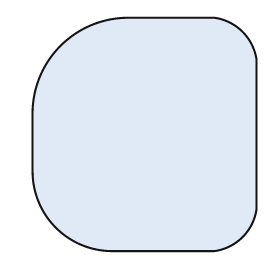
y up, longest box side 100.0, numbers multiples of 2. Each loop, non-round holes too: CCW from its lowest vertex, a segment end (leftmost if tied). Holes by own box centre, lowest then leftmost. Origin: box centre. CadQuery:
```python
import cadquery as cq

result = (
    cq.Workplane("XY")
    .moveTo(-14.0, -50.0)
    .lineTo(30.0, -50.0)
    .threePointArc((42.0, -44.0), (48.0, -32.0))
    .lineTo(48.0, 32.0)
    .threePointArc((42.0, 44.0), (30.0, 50.0))
    .lineTo(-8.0, 50.0)
    .threePointArc((-36.0, 38.0), (-48.0, 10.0))
    .lineTo(-48.0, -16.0)
    .threePointArc((-38.0, -40.0), (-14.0, -50.0))
    .close()
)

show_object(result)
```